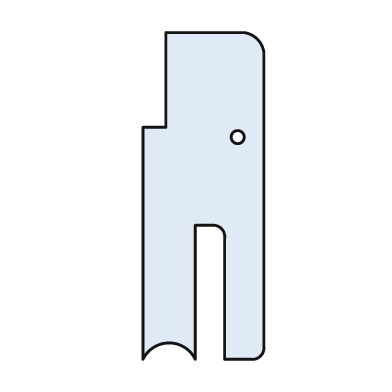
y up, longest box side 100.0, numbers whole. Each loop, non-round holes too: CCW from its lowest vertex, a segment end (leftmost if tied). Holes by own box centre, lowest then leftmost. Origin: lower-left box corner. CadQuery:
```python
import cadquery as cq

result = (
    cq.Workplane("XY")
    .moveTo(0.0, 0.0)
    .threePointArc((8.0, 5.0), (16.0, 0.0))
    .lineTo(16.0, 41.0)
    .lineTo(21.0, 41.0)
    .threePointArc((24.0, 40.0), (25.0, 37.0))
    .lineTo(25.0, 0.0)
    .lineTo(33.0, 0.0)
    .threePointArc((36.0, 1.0), (37.0, 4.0))
    .lineTo(37.0, 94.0)
    .threePointArc((35.0, 98.0), (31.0, 100.0))
    .lineTo(7.0, 100.0)
    .lineTo(7.0, 71.0)
    .lineTo(0.0, 71.0)
    .close()
    .moveTo(29.0, 68.0)
    .circle(2.0)
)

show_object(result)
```